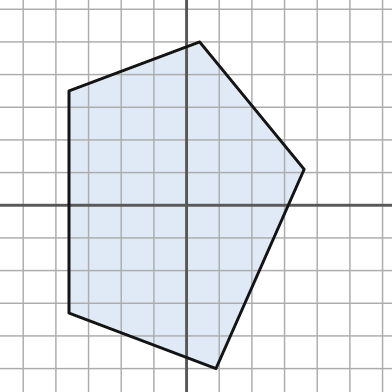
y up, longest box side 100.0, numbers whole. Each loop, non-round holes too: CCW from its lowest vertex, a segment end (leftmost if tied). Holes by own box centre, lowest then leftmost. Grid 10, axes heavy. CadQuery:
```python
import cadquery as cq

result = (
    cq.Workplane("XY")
    .moveTo(9.0, -50.0)
    .lineTo(36.0, 11.0)
    .lineTo(4.0, 50.0)
    .lineTo(-36.0, 35.0)
    .lineTo(-36.0, -33.0)
    .close()
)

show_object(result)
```